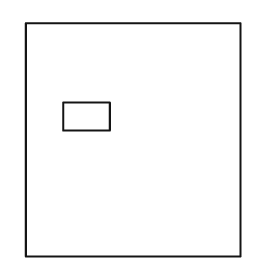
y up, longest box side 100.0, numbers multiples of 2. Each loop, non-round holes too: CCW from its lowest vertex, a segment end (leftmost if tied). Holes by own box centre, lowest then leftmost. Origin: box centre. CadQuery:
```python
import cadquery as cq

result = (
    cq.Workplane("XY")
    .moveTo(-46.0, -50.0)
    .lineTo(46.0, -50.0)
    .lineTo(46.0, 50.0)
    .lineTo(-46.0, 50.0)
    .close()
    .moveTo(-30.0, 4.0)
    .lineTo(-10.0, 4.0)
    .lineTo(-10.0, 16.0)
    .lineTo(-30.0, 16.0)
    .close()
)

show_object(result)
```